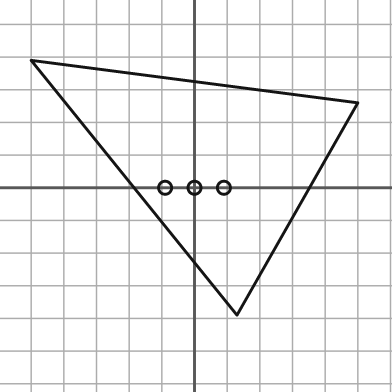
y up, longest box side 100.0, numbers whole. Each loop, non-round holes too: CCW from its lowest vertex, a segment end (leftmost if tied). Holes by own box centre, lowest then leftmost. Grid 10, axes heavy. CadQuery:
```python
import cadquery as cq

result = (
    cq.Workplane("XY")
    .moveTo(13.0, -39.0)
    .lineTo(50.0, 26.0)
    .lineTo(-50.0, 39.0)
    .close()
    .moveTo(-9.0, 0.0)
    .circle(2.0)
    .moveTo(0.0, 0.0)
    .circle(2.0)
    .moveTo(9.0, 0.0)
    .circle(2.0)
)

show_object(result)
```